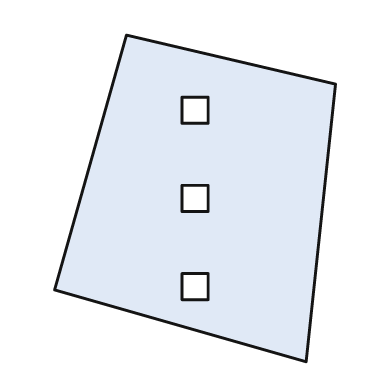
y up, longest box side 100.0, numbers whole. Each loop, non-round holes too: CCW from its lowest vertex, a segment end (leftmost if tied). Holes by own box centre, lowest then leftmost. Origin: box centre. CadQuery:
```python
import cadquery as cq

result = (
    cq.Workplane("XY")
    .moveTo(34.0, -50.0)
    .lineTo(43.0, 35.0)
    .lineTo(-21.0, 50.0)
    .lineTo(-43.0, -28.0)
    .close()
    .moveTo(-4.0, -31.0)
    .lineTo(4.0, -31.0)
    .lineTo(4.0, -23.0)
    .lineTo(-4.0, -23.0)
    .close()
    .moveTo(-4.0, -4.0)
    .lineTo(4.0, -4.0)
    .lineTo(4.0, 4.0)
    .lineTo(-4.0, 4.0)
    .close()
    .moveTo(-4.0, 23.0)
    .lineTo(4.0, 23.0)
    .lineTo(4.0, 31.0)
    .lineTo(-4.0, 31.0)
    .close()
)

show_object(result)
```